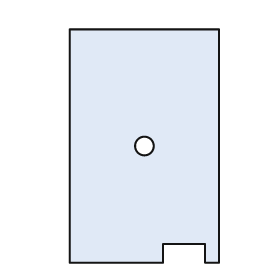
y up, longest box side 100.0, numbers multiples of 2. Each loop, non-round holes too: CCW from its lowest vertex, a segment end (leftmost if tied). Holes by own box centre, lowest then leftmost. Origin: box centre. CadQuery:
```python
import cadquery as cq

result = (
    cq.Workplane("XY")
    .moveTo(-32.0, -50.0)
    .lineTo(8.0, -50.0)
    .lineTo(8.0, -42.0)
    .lineTo(26.0, -42.0)
    .lineTo(26.0, -50.0)
    .lineTo(32.0, -50.0)
    .lineTo(32.0, 50.0)
    .lineTo(-32.0, 50.0)
    .close()
    .moveTo(0.0, 0.0)
    .circle(4.0)
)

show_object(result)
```